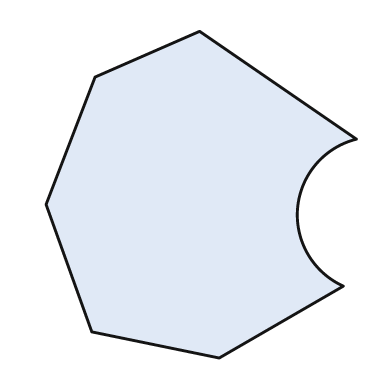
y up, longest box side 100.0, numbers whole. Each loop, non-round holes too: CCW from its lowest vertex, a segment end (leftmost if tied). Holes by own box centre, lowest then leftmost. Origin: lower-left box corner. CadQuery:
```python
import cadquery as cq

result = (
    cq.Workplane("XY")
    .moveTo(53.0, 0.0)
    .lineTo(91.0, 22.0)
    .threePointArc((77.0, 46.0), (95.0, 67.0))
    .lineTo(47.0, 100.0)
    .lineTo(15.0, 86.0)
    .lineTo(0.0, 47.0)
    .lineTo(14.0, 8.0)
    .close()
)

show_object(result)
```